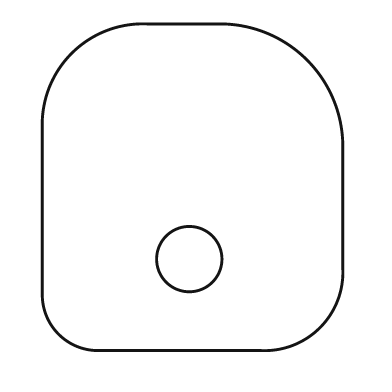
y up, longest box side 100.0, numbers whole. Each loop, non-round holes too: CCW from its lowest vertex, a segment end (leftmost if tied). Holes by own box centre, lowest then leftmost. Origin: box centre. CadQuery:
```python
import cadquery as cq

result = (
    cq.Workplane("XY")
    .moveTo(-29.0, -50.0)
    .lineTo(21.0, -50.0)
    .threePointArc((39.0, -43.0), (46.0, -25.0))
    .lineTo(46.0, 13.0)
    .threePointArc((35.0, 39.0), (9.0, 50.0))
    .lineTo(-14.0, 50.0)
    .threePointArc((-37.0, 41.0), (-46.0, 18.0))
    .lineTo(-46.0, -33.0)
    .threePointArc((-41.0, -45.0), (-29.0, -50.0))
    .close()
    .moveTo(-1.0, -22.0)
    .circle(10.0)
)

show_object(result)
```